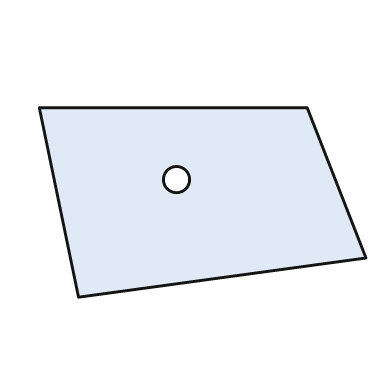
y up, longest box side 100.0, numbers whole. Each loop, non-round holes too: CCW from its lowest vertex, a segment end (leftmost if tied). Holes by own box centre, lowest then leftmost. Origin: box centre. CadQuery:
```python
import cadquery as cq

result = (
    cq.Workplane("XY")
    .moveTo(-38.0, -29.0)
    .lineTo(50.0, -17.0)
    .lineTo(32.0, 29.0)
    .lineTo(-50.0, 29.0)
    .close()
    .moveTo(-8.0, 7.0)
    .circle(4.0)
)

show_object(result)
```